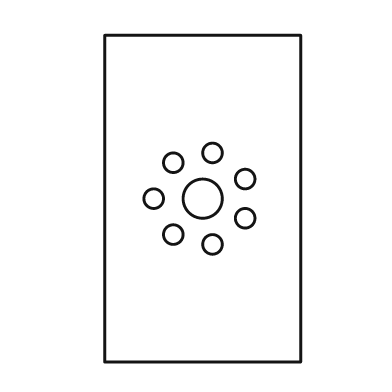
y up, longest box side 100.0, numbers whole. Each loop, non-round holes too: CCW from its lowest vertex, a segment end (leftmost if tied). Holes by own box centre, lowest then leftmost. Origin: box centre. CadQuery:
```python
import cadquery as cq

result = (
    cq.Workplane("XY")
    .moveTo(-30.0, -50.0)
    .lineTo(30.0, -50.0)
    .lineTo(30.0, 50.0)
    .lineTo(-30.0, 50.0)
    .close()
    .moveTo(3.0, -14.0)
    .circle(3.0)
    .moveTo(-9.0, -11.0)
    .circle(3.0)
    .moveTo(13.0, -6.0)
    .circle(3.0)
    .moveTo(-15.0, 0.0)
    .circle(3.0)
    .moveTo(0.0, 0.0)
    .circle(6.0)
    .moveTo(13.0, 6.0)
    .circle(3.0)
    .moveTo(-9.0, 11.0)
    .circle(3.0)
    .moveTo(3.0, 14.0)
    .circle(3.0)
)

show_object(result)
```